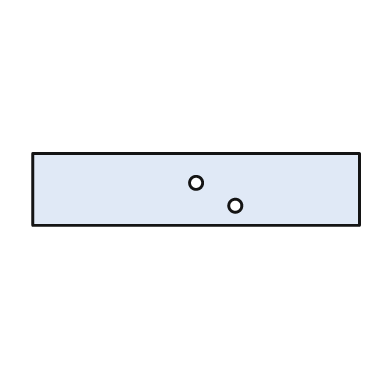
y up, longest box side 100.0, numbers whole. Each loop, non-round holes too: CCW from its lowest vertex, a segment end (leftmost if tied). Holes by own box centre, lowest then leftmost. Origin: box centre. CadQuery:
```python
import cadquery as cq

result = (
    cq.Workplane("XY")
    .moveTo(-50.0, -11.0)
    .lineTo(50.0, -11.0)
    .lineTo(50.0, 11.0)
    .lineTo(-50.0, 11.0)
    .close()
    .moveTo(12.0, -5.0)
    .circle(2.0)
    .moveTo(0.0, 2.0)
    .circle(2.0)
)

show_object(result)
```